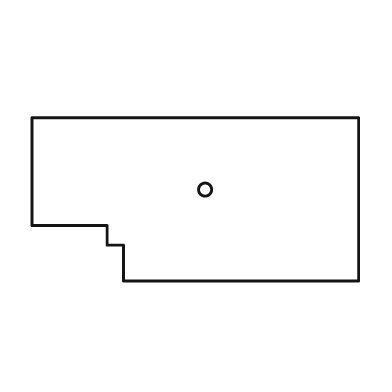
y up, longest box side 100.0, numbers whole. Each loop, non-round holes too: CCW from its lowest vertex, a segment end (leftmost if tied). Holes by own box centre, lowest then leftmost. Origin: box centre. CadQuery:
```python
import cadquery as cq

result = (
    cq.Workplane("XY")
    .moveTo(-22.0, -25.0)
    .lineTo(50.0, -25.0)
    .lineTo(50.0, 25.0)
    .lineTo(-50.0, 25.0)
    .lineTo(-50.0, -8.0)
    .lineTo(-27.0, -8.0)
    .lineTo(-27.0, -14.0)
    .lineTo(-22.0, -14.0)
    .close()
    .moveTo(3.0, 3.0)
    .circle(2.0)
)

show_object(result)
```